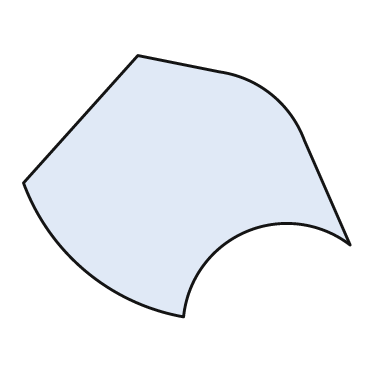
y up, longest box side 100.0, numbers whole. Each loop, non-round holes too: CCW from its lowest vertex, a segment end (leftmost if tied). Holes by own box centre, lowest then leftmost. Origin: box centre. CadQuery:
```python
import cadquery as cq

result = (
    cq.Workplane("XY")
    .moveTo(-1.0, -40.0)
    .threePointArc((18.0, -14.0), (50.0, -18.0))
    .lineTo(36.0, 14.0)
    .threePointArc((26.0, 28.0), (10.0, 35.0))
    .lineTo(-15.0, 40.0)
    .lineTo(-50.0, 1.0)
    .threePointArc((-31.0, -26.0), (-1.0, -40.0))
    .close()
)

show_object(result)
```